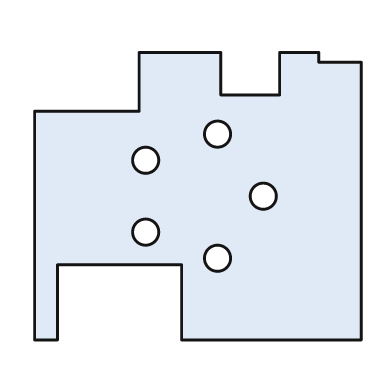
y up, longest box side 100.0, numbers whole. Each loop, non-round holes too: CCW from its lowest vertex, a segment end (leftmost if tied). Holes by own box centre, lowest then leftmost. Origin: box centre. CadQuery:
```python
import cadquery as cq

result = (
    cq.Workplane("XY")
    .moveTo(-50.0, -44.0)
    .lineTo(-43.0, -44.0)
    .lineTo(-43.0, -21.0)
    .lineTo(-5.0, -21.0)
    .lineTo(-5.0, -44.0)
    .lineTo(50.0, -44.0)
    .lineTo(50.0, 41.0)
    .lineTo(37.0, 41.0)
    .lineTo(37.0, 44.0)
    .lineTo(25.0, 44.0)
    .lineTo(25.0, 31.0)
    .lineTo(7.0, 31.0)
    .lineTo(7.0, 44.0)
    .lineTo(-18.0, 44.0)
    .lineTo(-18.0, 26.0)
    .lineTo(-50.0, 26.0)
    .close()
    .moveTo(6.0, -19.0)
    .circle(4.0)
    .moveTo(-16.0, -11.0)
    .circle(4.0)
    .moveTo(20.0, 0.0)
    .circle(4.0)
    .moveTo(-16.0, 11.0)
    .circle(4.0)
    .moveTo(6.0, 19.0)
    .circle(4.0)
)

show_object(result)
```